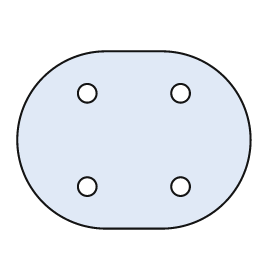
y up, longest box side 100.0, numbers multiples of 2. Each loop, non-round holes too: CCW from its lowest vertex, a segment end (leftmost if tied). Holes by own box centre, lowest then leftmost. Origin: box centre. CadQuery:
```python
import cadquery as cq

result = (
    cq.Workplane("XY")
    .moveTo(-12.0, -38.0)
    .lineTo(12.0, -38.0)
    .threePointArc((50.0, 0.0), (12.0, 38.0))
    .lineTo(-12.0, 38.0)
    .threePointArc((-50.0, 0.0), (-12.0, -38.0))
    .close()
    .moveTo(-20.0, -20.0)
    .circle(4.0)
    .moveTo(20.0, -20.0)
    .circle(4.0)
    .moveTo(-20.0, 20.0)
    .circle(4.0)
    .moveTo(20.0, 20.0)
    .circle(4.0)
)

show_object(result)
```